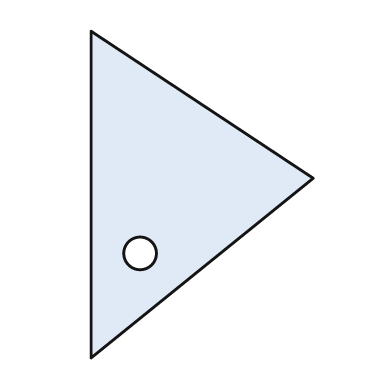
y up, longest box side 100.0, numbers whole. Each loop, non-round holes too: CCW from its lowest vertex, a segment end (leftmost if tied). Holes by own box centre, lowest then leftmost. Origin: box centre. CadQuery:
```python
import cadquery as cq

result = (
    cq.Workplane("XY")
    .moveTo(-34.0, -50.0)
    .lineTo(34.0, 5.0)
    .lineTo(-34.0, 50.0)
    .close()
    .moveTo(-19.0, -18.0)
    .circle(5.0)
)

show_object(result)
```